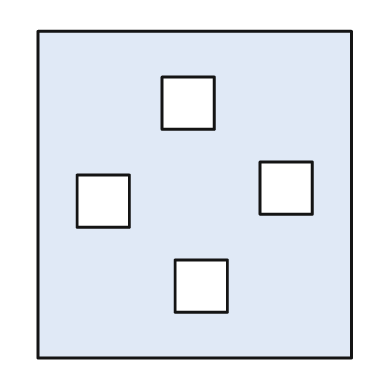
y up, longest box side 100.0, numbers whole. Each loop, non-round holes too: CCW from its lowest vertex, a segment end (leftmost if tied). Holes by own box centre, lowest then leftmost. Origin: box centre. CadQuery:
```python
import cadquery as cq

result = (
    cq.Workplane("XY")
    .moveTo(-48.0, -50.0)
    .lineTo(48.0, -50.0)
    .lineTo(48.0, 50.0)
    .lineTo(-48.0, 50.0)
    .close()
    .moveTo(-6.0, -36.0)
    .lineTo(10.0, -36.0)
    .lineTo(10.0, -20.0)
    .lineTo(-6.0, -20.0)
    .close()
    .moveTo(-36.0, -10.0)
    .lineTo(-20.0, -10.0)
    .lineTo(-20.0, 6.0)
    .lineTo(-36.0, 6.0)
    .close()
    .moveTo(20.0, -6.0)
    .lineTo(36.0, -6.0)
    .lineTo(36.0, 10.0)
    .lineTo(20.0, 10.0)
    .close()
    .moveTo(-10.0, 20.0)
    .lineTo(6.0, 20.0)
    .lineTo(6.0, 36.0)
    .lineTo(-10.0, 36.0)
    .close()
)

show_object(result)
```